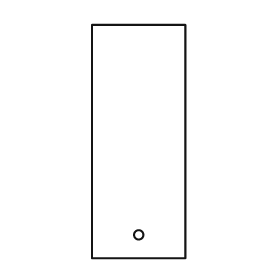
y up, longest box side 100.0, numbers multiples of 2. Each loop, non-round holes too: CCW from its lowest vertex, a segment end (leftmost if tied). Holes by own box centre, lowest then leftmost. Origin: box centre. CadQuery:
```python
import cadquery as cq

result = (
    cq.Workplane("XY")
    .moveTo(-20.0, -50.0)
    .lineTo(20.0, -50.0)
    .lineTo(20.0, 50.0)
    .lineTo(-20.0, 50.0)
    .close()
    .moveTo(0.0, -40.0)
    .circle(2.0)
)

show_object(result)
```